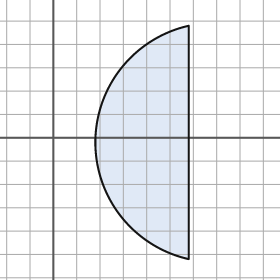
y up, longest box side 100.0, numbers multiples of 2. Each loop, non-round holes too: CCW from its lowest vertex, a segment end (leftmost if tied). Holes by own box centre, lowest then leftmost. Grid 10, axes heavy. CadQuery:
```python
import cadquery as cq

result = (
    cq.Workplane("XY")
    .moveTo(58.0, -52.0)
    .lineTo(58.0, 48.0)
    .threePointArc((18.0, -2.0), (58.0, -52.0))
    .close()
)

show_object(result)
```